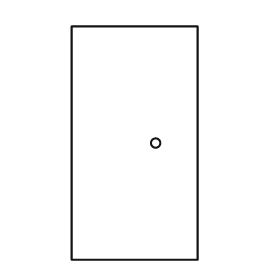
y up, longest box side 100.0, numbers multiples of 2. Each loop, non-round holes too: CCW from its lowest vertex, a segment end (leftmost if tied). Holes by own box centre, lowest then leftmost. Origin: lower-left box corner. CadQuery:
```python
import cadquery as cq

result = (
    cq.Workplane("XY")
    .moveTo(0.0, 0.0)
    .lineTo(54.0, 0.0)
    .lineTo(54.0, 100.0)
    .lineTo(0.0, 100.0)
    .close()
    .moveTo(36.0, 50.0)
    .circle(2.0)
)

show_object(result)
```